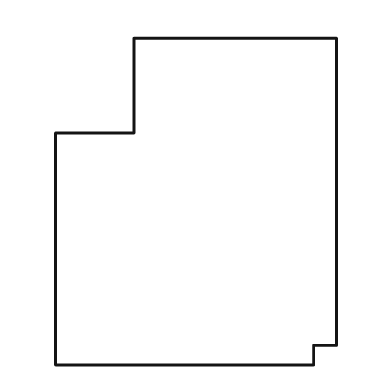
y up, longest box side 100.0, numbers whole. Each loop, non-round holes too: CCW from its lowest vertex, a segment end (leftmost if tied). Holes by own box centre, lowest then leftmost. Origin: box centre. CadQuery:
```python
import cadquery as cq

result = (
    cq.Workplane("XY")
    .moveTo(-43.0, -50.0)
    .lineTo(36.0, -50.0)
    .lineTo(36.0, -44.0)
    .lineTo(43.0, -44.0)
    .lineTo(43.0, 50.0)
    .lineTo(-19.0, 50.0)
    .lineTo(-19.0, 21.0)
    .lineTo(-43.0, 21.0)
    .close()
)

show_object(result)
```